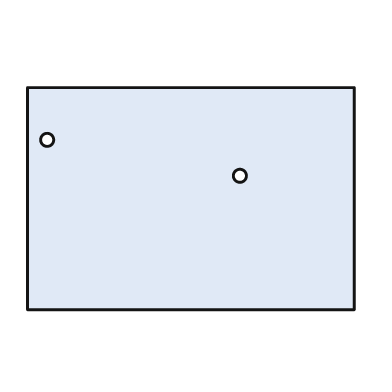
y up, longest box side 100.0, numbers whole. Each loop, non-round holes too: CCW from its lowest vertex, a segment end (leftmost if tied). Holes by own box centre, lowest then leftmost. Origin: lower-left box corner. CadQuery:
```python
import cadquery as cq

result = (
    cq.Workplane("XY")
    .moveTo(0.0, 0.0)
    .lineTo(100.0, 0.0)
    .lineTo(100.0, 68.0)
    .lineTo(0.0, 68.0)
    .close()
    .moveTo(65.0, 41.0)
    .circle(2.0)
    .moveTo(6.0, 52.0)
    .circle(2.0)
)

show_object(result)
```